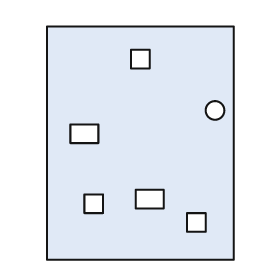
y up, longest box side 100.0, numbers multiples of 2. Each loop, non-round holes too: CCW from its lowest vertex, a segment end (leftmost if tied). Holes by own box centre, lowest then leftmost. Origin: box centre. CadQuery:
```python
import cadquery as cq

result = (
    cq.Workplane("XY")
    .moveTo(-40.0, -50.0)
    .lineTo(40.0, -50.0)
    .lineTo(40.0, 50.0)
    .lineTo(-40.0, 50.0)
    .close()
    .moveTo(20.0, -38.0)
    .lineTo(28.0, -38.0)
    .lineTo(28.0, -30.0)
    .lineTo(20.0, -30.0)
    .close()
    .moveTo(-24.0, -30.0)
    .lineTo(-16.0, -30.0)
    .lineTo(-16.0, -22.0)
    .lineTo(-24.0, -22.0)
    .close()
    .moveTo(-2.0, -28.0)
    .lineTo(10.0, -28.0)
    .lineTo(10.0, -20.0)
    .lineTo(-2.0, -20.0)
    .close()
    .moveTo(-30.0, 0.0)
    .lineTo(-18.0, 0.0)
    .lineTo(-18.0, 8.0)
    .lineTo(-30.0, 8.0)
    .close()
    .moveTo(32.0, 14.0)
    .circle(4.0)
    .moveTo(-4.0, 32.0)
    .lineTo(4.0, 32.0)
    .lineTo(4.0, 40.0)
    .lineTo(-4.0, 40.0)
    .close()
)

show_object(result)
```